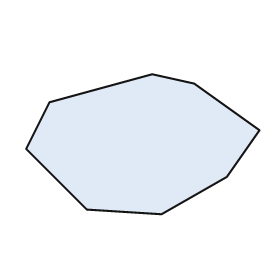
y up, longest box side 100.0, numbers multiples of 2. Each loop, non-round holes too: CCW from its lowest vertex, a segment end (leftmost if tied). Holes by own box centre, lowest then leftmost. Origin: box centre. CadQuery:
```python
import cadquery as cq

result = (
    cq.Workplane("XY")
    .moveTo(8.0, -30.0)
    .lineTo(36.0, -14.0)
    .lineTo(50.0, 6.0)
    .lineTo(22.0, 26.0)
    .lineTo(4.0, 30.0)
    .lineTo(-40.0, 18.0)
    .lineTo(-50.0, -2.0)
    .lineTo(-24.0, -28.0)
    .close()
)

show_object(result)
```